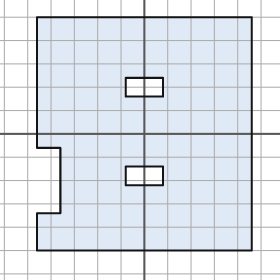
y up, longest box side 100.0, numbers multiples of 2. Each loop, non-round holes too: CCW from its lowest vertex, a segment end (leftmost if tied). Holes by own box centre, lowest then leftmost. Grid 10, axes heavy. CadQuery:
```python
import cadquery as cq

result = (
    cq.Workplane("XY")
    .moveTo(-46.0, -50.0)
    .lineTo(46.0, -50.0)
    .lineTo(46.0, 50.0)
    .lineTo(-46.0, 50.0)
    .lineTo(-46.0, -6.0)
    .lineTo(-36.0, -6.0)
    .lineTo(-36.0, -34.0)
    .lineTo(-46.0, -34.0)
    .close()
    .moveTo(-8.0, -22.0)
    .lineTo(8.0, -22.0)
    .lineTo(8.0, -14.0)
    .lineTo(-8.0, -14.0)
    .close()
    .moveTo(-8.0, 16.0)
    .lineTo(8.0, 16.0)
    .lineTo(8.0, 24.0)
    .lineTo(-8.0, 24.0)
    .close()
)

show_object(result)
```